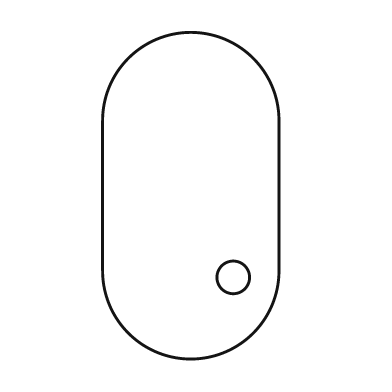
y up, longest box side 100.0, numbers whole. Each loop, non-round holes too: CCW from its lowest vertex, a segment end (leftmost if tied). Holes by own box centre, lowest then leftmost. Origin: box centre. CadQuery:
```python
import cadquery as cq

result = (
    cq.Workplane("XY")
    .moveTo(-27.0, -23.0)
    .threePointArc((0.0, -50.0), (27.0, -23.0))
    .lineTo(27.0, 23.0)
    .threePointArc((0.0, 50.0), (-27.0, 23.0))
    .close()
    .moveTo(13.0, -25.0)
    .circle(5.0)
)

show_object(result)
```